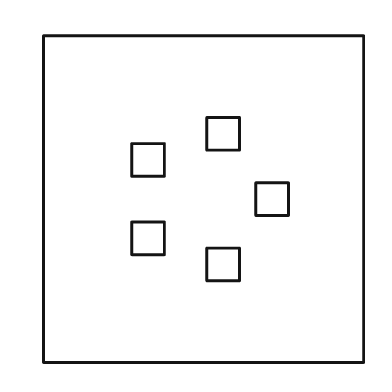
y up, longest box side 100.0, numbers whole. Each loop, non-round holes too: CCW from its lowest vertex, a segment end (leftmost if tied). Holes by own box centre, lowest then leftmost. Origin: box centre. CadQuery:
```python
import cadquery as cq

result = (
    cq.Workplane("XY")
    .moveTo(-49.0, -50.0)
    .lineTo(49.0, -50.0)
    .lineTo(49.0, 50.0)
    .lineTo(-49.0, 50.0)
    .close()
    .moveTo(1.0, -25.0)
    .lineTo(11.0, -25.0)
    .lineTo(11.0, -15.0)
    .lineTo(1.0, -15.0)
    .close()
    .moveTo(-22.0, -17.0)
    .lineTo(-12.0, -17.0)
    .lineTo(-12.0, -7.0)
    .lineTo(-22.0, -7.0)
    .close()
    .moveTo(16.0, -5.0)
    .lineTo(26.0, -5.0)
    .lineTo(26.0, 5.0)
    .lineTo(16.0, 5.0)
    .close()
    .moveTo(-22.0, 7.0)
    .lineTo(-12.0, 7.0)
    .lineTo(-12.0, 17.0)
    .lineTo(-22.0, 17.0)
    .close()
    .moveTo(1.0, 15.0)
    .lineTo(11.0, 15.0)
    .lineTo(11.0, 25.0)
    .lineTo(1.0, 25.0)
    .close()
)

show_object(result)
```